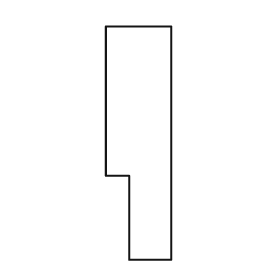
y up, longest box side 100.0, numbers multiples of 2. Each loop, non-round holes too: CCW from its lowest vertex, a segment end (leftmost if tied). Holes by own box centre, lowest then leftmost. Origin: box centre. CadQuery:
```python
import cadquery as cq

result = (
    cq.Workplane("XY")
    .moveTo(-4.0, -50.0)
    .lineTo(14.0, -50.0)
    .lineTo(14.0, 50.0)
    .lineTo(-14.0, 50.0)
    .lineTo(-14.0, -14.0)
    .lineTo(-4.0, -14.0)
    .close()
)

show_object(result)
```